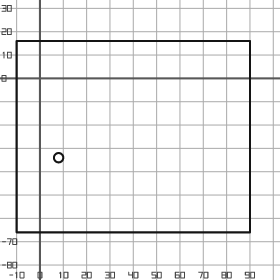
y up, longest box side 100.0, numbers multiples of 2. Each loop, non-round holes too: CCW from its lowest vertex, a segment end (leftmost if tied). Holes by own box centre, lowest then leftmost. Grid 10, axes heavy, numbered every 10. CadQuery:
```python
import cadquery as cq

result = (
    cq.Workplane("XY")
    .moveTo(-10.0, -66.0)
    .lineTo(90.0, -66.0)
    .lineTo(90.0, 16.0)
    .lineTo(-10.0, 16.0)
    .close()
    .moveTo(8.0, -34.0)
    .circle(2.0)
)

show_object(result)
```